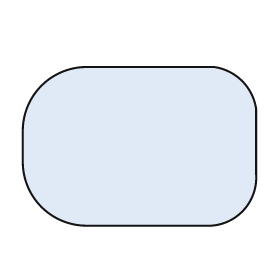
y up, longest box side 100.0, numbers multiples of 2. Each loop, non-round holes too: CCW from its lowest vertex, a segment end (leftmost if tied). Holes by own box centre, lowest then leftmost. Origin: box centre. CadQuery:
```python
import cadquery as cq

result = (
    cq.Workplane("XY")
    .moveTo(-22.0, -34.0)
    .lineTo(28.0, -34.0)
    .threePointArc((44.0, -28.0), (50.0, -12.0))
    .lineTo(50.0, 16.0)
    .threePointArc((44.0, 28.0), (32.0, 34.0))
    .lineTo(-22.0, 34.0)
    .threePointArc((-42.0, 26.0), (-50.0, 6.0))
    .lineTo(-50.0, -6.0)
    .threePointArc((-42.0, -26.0), (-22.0, -34.0))
    .close()
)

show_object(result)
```